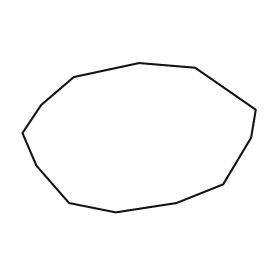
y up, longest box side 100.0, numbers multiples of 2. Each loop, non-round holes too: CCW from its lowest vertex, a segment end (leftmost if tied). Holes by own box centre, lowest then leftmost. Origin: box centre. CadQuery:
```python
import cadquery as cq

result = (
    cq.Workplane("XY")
    .moveTo(-10.0, -32.0)
    .lineTo(16.0, -28.0)
    .lineTo(36.0, -20.0)
    .lineTo(48.0, 0.0)
    .lineTo(50.0, 12.0)
    .lineTo(24.0, 30.0)
    .lineTo(0.0, 32.0)
    .lineTo(-28.0, 26.0)
    .lineTo(-42.0, 14.0)
    .lineTo(-50.0, 2.0)
    .lineTo(-44.0, -12.0)
    .lineTo(-30.0, -28.0)
    .close()
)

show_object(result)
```